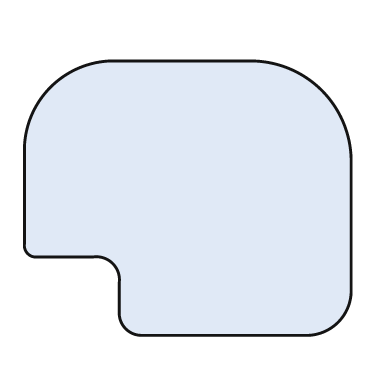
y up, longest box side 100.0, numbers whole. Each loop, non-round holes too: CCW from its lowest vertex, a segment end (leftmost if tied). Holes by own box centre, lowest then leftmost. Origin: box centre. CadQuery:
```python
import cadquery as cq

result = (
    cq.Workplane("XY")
    .moveTo(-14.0, -42.0)
    .lineTo(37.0, -42.0)
    .threePointArc((46.0, -38.0), (50.0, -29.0))
    .lineTo(50.0, 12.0)
    .threePointArc((41.0, 33.0), (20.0, 42.0))
    .lineTo(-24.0, 42.0)
    .threePointArc((-42.0, 34.0), (-50.0, 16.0))
    .lineTo(-50.0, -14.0)
    .threePointArc((-49.0, -17.0), (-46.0, -18.0))
    .lineTo(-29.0, -18.0)
    .threePointArc((-23.0, -20.0), (-21.0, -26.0))
    .lineTo(-21.0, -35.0)
    .threePointArc((-19.0, -40.0), (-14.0, -42.0))
    .close()
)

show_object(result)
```